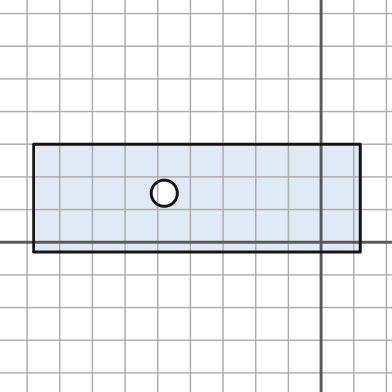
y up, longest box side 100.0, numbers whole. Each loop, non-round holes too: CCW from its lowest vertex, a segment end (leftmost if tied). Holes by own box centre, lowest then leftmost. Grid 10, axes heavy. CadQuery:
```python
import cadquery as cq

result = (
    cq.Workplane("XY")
    .moveTo(-88.0, -3.0)
    .lineTo(12.0, -3.0)
    .lineTo(12.0, 30.0)
    .lineTo(-88.0, 30.0)
    .close()
    .moveTo(-48.0, 15.0)
    .circle(4.0)
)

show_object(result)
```